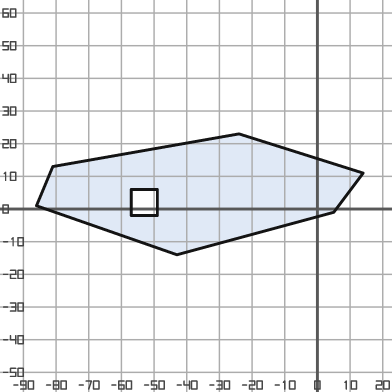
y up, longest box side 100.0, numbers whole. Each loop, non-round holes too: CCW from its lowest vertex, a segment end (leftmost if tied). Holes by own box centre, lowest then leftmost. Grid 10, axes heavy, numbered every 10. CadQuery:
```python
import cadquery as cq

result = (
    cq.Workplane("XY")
    .moveTo(-43.0, -14.0)
    .lineTo(5.0, -1.0)
    .lineTo(14.0, 11.0)
    .lineTo(-24.0, 23.0)
    .lineTo(-81.0, 13.0)
    .lineTo(-86.0, 1.0)
    .close()
    .moveTo(-57.0, -2.0)
    .lineTo(-49.0, -2.0)
    .lineTo(-49.0, 6.0)
    .lineTo(-57.0, 6.0)
    .close()
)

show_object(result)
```